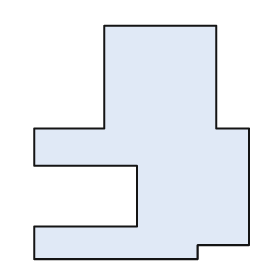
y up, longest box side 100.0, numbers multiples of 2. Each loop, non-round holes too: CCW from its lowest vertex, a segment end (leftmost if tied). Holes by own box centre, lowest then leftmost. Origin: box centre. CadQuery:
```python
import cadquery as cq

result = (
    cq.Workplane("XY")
    .moveTo(-46.0, -50.0)
    .lineTo(24.0, -50.0)
    .lineTo(24.0, -44.0)
    .lineTo(46.0, -44.0)
    .lineTo(46.0, 6.0)
    .lineTo(32.0, 6.0)
    .lineTo(32.0, 50.0)
    .lineTo(-16.0, 50.0)
    .lineTo(-16.0, 6.0)
    .lineTo(-46.0, 6.0)
    .lineTo(-46.0, -10.0)
    .lineTo(-2.0, -10.0)
    .lineTo(-2.0, -36.0)
    .lineTo(-46.0, -36.0)
    .close()
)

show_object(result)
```